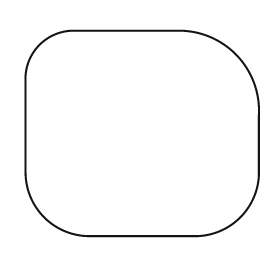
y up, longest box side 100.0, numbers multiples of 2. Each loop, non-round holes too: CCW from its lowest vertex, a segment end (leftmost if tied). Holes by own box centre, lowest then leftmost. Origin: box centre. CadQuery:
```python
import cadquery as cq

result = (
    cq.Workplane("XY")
    .moveTo(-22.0, -44.0)
    .lineTo(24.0, -44.0)
    .threePointArc((42.0, -36.0), (50.0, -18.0))
    .lineTo(50.0, 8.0)
    .threePointArc((40.0, 34.0), (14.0, 44.0))
    .lineTo(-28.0, 44.0)
    .threePointArc((-44.0, 38.0), (-50.0, 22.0))
    .lineTo(-50.0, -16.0)
    .threePointArc((-42.0, -36.0), (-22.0, -44.0))
    .close()
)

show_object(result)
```